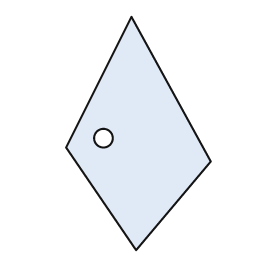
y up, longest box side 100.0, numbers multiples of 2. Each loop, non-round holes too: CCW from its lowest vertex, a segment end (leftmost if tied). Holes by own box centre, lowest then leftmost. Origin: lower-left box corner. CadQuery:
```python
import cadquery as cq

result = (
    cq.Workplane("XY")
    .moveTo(30.0, 0.0)
    .lineTo(62.0, 38.0)
    .lineTo(28.0, 100.0)
    .lineTo(0.0, 44.0)
    .close()
    .moveTo(16.0, 48.0)
    .circle(4.0)
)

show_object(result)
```